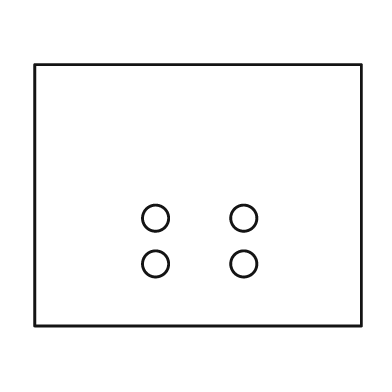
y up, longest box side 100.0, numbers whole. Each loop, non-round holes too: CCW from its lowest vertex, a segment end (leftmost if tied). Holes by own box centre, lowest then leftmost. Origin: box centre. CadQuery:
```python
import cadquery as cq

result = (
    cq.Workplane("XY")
    .moveTo(-50.0, -40.0)
    .lineTo(50.0, -40.0)
    .lineTo(50.0, 40.0)
    .lineTo(-50.0, 40.0)
    .close()
    .moveTo(-13.0, -21.0)
    .circle(4.0)
    .moveTo(14.0, -21.0)
    .circle(4.0)
    .moveTo(-13.0, -7.0)
    .circle(4.0)
    .moveTo(14.0, -7.0)
    .circle(4.0)
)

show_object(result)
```